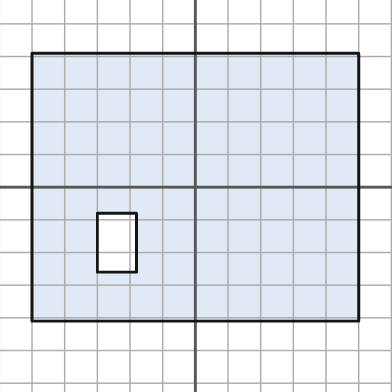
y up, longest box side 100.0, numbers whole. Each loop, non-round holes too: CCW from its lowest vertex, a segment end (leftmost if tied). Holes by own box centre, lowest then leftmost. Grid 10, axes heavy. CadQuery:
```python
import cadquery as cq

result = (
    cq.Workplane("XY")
    .moveTo(-50.0, -41.0)
    .lineTo(50.0, -41.0)
    .lineTo(50.0, 41.0)
    .lineTo(-50.0, 41.0)
    .close()
    .moveTo(-30.0, -26.0)
    .lineTo(-18.0, -26.0)
    .lineTo(-18.0, -8.0)
    .lineTo(-30.0, -8.0)
    .close()
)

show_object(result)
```